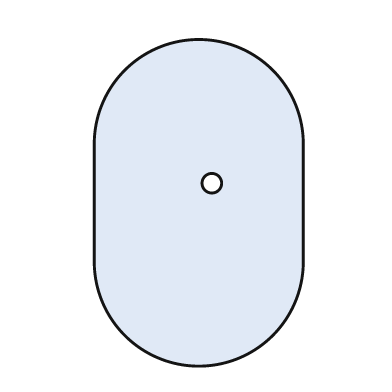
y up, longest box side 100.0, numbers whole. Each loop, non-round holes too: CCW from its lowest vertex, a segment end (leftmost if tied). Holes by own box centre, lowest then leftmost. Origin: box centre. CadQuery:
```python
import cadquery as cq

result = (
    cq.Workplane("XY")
    .moveTo(-32.0, -18.0)
    .threePointArc((0.0, -50.0), (32.0, -18.0))
    .lineTo(32.0, 18.0)
    .threePointArc((0.0, 50.0), (-32.0, 18.0))
    .close()
    .moveTo(4.0, 6.0)
    .circle(3.0)
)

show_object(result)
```